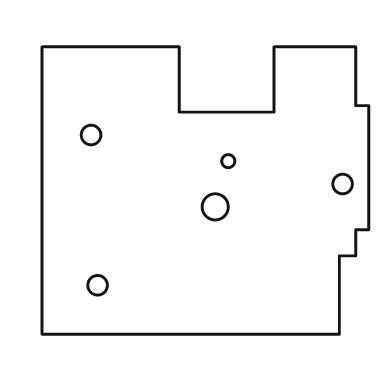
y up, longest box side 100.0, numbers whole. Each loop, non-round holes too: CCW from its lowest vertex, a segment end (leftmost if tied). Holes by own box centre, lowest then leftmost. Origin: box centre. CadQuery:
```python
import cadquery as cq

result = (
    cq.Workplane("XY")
    .moveTo(-50.0, -44.0)
    .lineTo(41.0, -44.0)
    .lineTo(41.0, -20.0)
    .lineTo(46.0, -20.0)
    .lineTo(46.0, -12.0)
    .lineTo(50.0, -12.0)
    .lineTo(50.0, 26.0)
    .lineTo(46.0, 26.0)
    .lineTo(46.0, 44.0)
    .lineTo(21.0, 44.0)
    .lineTo(21.0, 24.0)
    .lineTo(-8.0, 24.0)
    .lineTo(-8.0, 44.0)
    .lineTo(-50.0, 44.0)
    .close()
    .moveTo(-33.0, -29.0)
    .circle(3.0)
    .moveTo(3.0, -5.0)
    .circle(4.0)
    .moveTo(42.0, 2.0)
    .circle(3.0)
    .moveTo(7.0, 9.0)
    .circle(2.0)
    .moveTo(-35.0, 17.0)
    .circle(3.0)
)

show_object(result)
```